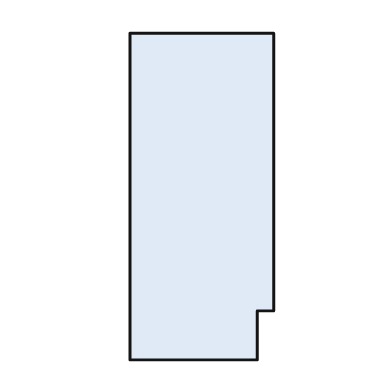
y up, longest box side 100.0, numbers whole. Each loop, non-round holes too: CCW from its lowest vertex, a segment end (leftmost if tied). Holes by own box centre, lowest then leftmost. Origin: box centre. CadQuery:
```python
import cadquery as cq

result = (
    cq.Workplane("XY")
    .moveTo(-22.0, -50.0)
    .lineTo(17.0, -50.0)
    .lineTo(17.0, -35.0)
    .lineTo(22.0, -35.0)
    .lineTo(22.0, 50.0)
    .lineTo(-22.0, 50.0)
    .close()
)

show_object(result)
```